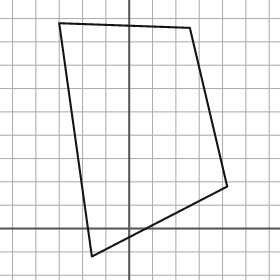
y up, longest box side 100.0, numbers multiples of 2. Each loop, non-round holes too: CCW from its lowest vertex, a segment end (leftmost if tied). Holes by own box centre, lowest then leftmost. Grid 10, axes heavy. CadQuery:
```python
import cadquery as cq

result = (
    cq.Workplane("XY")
    .moveTo(-16.0, -12.0)
    .lineTo(42.0, 18.0)
    .lineTo(26.0, 86.0)
    .lineTo(-30.0, 88.0)
    .close()
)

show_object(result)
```